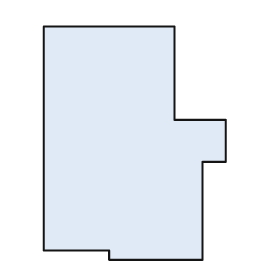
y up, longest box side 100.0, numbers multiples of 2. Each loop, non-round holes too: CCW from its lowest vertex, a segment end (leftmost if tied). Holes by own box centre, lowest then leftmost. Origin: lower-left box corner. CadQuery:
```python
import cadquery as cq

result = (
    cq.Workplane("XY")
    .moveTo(28.0, 0.0)
    .lineTo(68.0, 0.0)
    .lineTo(68.0, 42.0)
    .lineTo(78.0, 42.0)
    .lineTo(78.0, 60.0)
    .lineTo(56.0, 60.0)
    .lineTo(56.0, 100.0)
    .lineTo(0.0, 100.0)
    .lineTo(0.0, 4.0)
    .lineTo(28.0, 4.0)
    .close()
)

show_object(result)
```